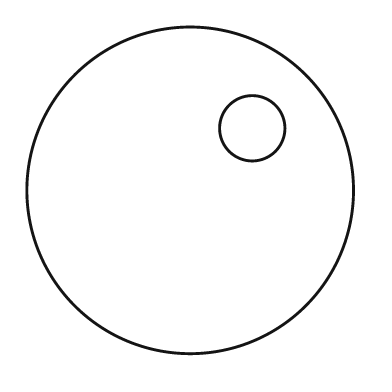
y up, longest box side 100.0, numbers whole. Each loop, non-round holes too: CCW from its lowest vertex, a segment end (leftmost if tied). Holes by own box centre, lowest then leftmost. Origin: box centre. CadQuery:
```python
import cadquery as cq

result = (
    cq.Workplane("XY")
    .moveTo(0.0, 0.0)
    .circle(50.0)
    .moveTo(19.0, 19.0)
    .circle(10.0)
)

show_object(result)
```